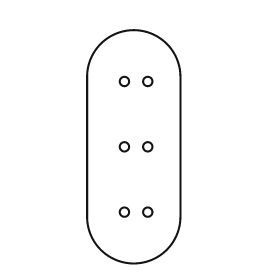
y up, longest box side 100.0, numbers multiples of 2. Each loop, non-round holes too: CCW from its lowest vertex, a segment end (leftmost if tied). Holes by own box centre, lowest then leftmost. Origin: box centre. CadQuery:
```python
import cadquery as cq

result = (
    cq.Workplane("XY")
    .moveTo(-20.0, -30.0)
    .threePointArc((0.0, -50.0), (20.0, -30.0))
    .lineTo(20.0, 30.0)
    .threePointArc((0.0, 50.0), (-20.0, 30.0))
    .close()
    .moveTo(-4.0, -28.0)
    .circle(2.0)
    .moveTo(6.0, -28.0)
    .circle(2.0)
    .moveTo(-4.0, 0.0)
    .circle(2.0)
    .moveTo(6.0, 0.0)
    .circle(2.0)
    .moveTo(-4.0, 28.0)
    .circle(2.0)
    .moveTo(6.0, 28.0)
    .circle(2.0)
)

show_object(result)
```